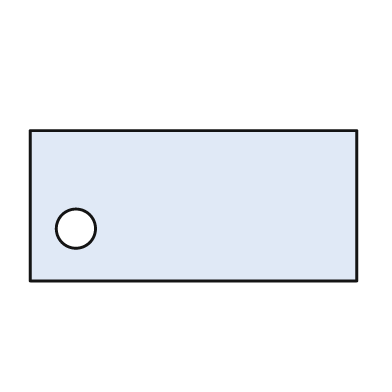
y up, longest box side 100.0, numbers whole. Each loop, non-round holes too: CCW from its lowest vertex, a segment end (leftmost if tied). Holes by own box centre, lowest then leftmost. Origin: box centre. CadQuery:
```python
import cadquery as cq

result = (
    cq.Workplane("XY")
    .moveTo(-50.0, -23.0)
    .lineTo(50.0, -23.0)
    .lineTo(50.0, 23.0)
    .lineTo(-50.0, 23.0)
    .close()
    .moveTo(-36.0, -7.0)
    .circle(6.0)
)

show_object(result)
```